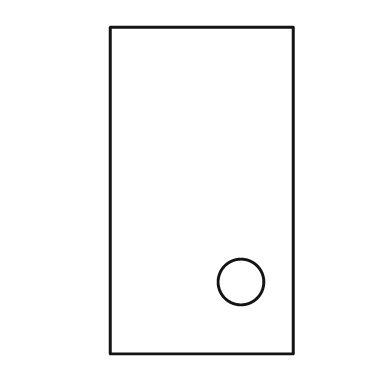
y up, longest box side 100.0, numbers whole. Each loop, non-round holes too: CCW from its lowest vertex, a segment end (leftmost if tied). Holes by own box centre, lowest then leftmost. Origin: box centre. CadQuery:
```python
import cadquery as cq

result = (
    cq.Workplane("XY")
    .moveTo(-28.0, -50.0)
    .lineTo(28.0, -50.0)
    .lineTo(28.0, 50.0)
    .lineTo(-28.0, 50.0)
    .close()
    .moveTo(12.0, -28.0)
    .circle(7.0)
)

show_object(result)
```